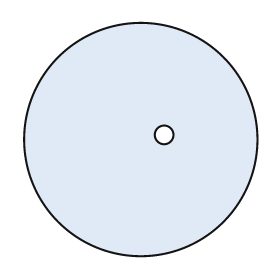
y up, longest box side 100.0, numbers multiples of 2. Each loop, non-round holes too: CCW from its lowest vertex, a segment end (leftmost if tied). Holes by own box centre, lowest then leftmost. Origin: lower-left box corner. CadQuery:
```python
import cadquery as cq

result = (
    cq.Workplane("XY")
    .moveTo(50.0, 50.0)
    .circle(50.0)
    .moveTo(60.0, 52.0)
    .circle(4.0)
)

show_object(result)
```